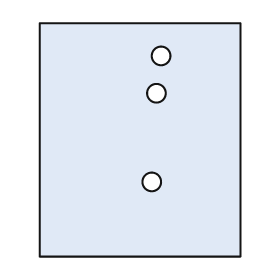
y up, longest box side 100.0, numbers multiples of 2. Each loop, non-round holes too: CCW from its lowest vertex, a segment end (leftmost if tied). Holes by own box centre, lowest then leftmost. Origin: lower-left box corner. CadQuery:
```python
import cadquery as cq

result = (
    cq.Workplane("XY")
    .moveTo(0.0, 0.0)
    .lineTo(86.0, 0.0)
    .lineTo(86.0, 100.0)
    .lineTo(0.0, 100.0)
    .close()
    .moveTo(48.0, 32.0)
    .circle(4.0)
    .moveTo(50.0, 70.0)
    .circle(4.0)
    .moveTo(52.0, 86.0)
    .circle(4.0)
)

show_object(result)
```